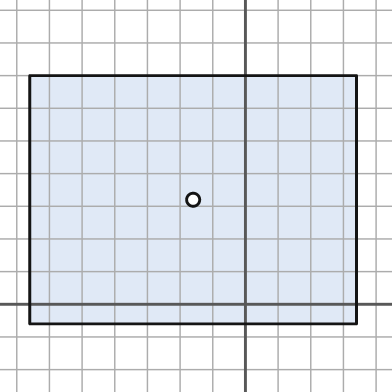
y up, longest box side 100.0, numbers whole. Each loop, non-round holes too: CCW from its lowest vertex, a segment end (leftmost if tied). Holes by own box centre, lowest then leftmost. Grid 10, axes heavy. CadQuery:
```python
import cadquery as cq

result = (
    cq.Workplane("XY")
    .moveTo(-66.0, -6.0)
    .lineTo(34.0, -6.0)
    .lineTo(34.0, 70.0)
    .lineTo(-66.0, 70.0)
    .close()
    .moveTo(-16.0, 32.0)
    .circle(2.0)
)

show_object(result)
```